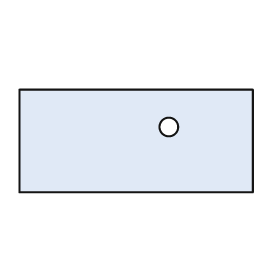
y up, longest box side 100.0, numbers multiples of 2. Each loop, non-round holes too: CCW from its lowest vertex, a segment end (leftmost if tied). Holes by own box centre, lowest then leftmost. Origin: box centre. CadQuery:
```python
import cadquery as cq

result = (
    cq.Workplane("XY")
    .moveTo(-50.0, -22.0)
    .lineTo(50.0, -22.0)
    .lineTo(50.0, 22.0)
    .lineTo(-50.0, 22.0)
    .close()
    .moveTo(14.0, 6.0)
    .circle(4.0)
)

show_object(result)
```